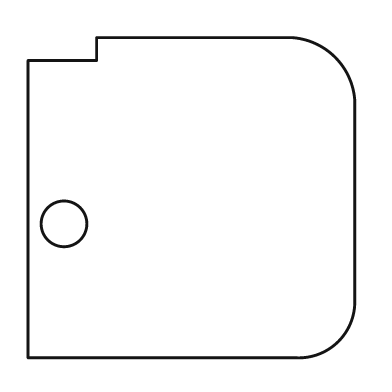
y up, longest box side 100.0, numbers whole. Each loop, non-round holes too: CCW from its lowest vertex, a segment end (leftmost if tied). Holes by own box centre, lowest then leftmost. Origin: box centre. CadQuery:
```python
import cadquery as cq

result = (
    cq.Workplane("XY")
    .moveTo(-50.0, -49.0)
    .lineTo(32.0, -49.0)
    .threePointArc((45.0, -44.0), (50.0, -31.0))
    .lineTo(50.0, 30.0)
    .threePointArc((44.0, 43.0), (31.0, 49.0))
    .lineTo(-29.0, 49.0)
    .lineTo(-29.0, 42.0)
    .lineTo(-50.0, 42.0)
    .close()
    .moveTo(-39.0, -8.0)
    .circle(7.0)
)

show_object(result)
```